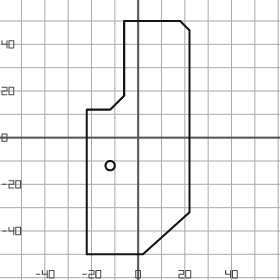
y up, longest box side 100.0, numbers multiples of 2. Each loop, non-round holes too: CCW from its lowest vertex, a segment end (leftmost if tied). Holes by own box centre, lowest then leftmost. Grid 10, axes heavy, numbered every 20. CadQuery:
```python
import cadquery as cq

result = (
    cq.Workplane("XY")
    .moveTo(-22.0, -50.0)
    .lineTo(2.0, -50.0)
    .lineTo(22.0, -32.0)
    .lineTo(22.0, 46.0)
    .lineTo(18.0, 50.0)
    .lineTo(-6.0, 50.0)
    .lineTo(-6.0, 18.0)
    .lineTo(-12.0, 12.0)
    .lineTo(-22.0, 12.0)
    .close()
    .moveTo(-12.0, -12.0)
    .circle(2.0)
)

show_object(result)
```